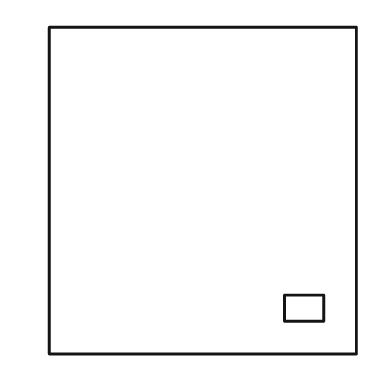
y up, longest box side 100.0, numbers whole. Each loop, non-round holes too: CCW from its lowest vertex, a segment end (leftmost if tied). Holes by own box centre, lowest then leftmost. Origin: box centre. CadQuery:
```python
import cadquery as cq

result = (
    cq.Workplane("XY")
    .moveTo(-47.0, -50.0)
    .lineTo(47.0, -50.0)
    .lineTo(47.0, 50.0)
    .lineTo(-47.0, 50.0)
    .close()
    .moveTo(25.0, -40.0)
    .lineTo(37.0, -40.0)
    .lineTo(37.0, -32.0)
    .lineTo(25.0, -32.0)
    .close()
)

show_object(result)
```